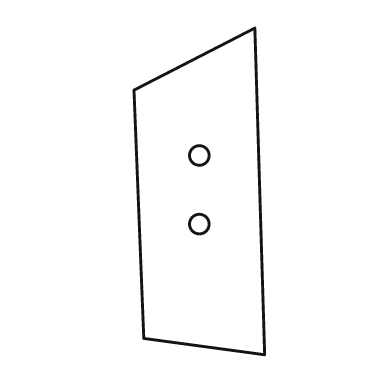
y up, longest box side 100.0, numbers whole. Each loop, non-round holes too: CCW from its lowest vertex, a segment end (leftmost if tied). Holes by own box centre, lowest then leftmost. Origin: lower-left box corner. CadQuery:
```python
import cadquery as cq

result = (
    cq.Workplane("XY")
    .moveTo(40.0, 0.0)
    .lineTo(37.0, 100.0)
    .lineTo(0.0, 81.0)
    .lineTo(3.0, 5.0)
    .close()
    .moveTo(20.0, 40.0)
    .circle(3.0)
    .moveTo(20.0, 61.0)
    .circle(3.0)
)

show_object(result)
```